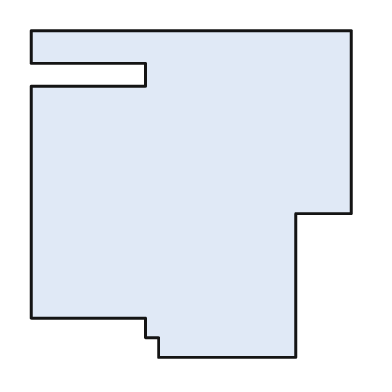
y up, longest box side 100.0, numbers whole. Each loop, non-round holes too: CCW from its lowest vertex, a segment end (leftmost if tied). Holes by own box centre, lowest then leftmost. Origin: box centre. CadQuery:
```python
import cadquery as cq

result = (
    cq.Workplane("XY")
    .moveTo(-10.0, -50.0)
    .lineTo(32.0, -50.0)
    .lineTo(32.0, -6.0)
    .lineTo(49.0, -6.0)
    .lineTo(49.0, 50.0)
    .lineTo(-49.0, 50.0)
    .lineTo(-49.0, 40.0)
    .lineTo(-14.0, 40.0)
    .lineTo(-14.0, 33.0)
    .lineTo(-49.0, 33.0)
    .lineTo(-49.0, -38.0)
    .lineTo(-14.0, -38.0)
    .lineTo(-14.0, -44.0)
    .lineTo(-10.0, -44.0)
    .close()
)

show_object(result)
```